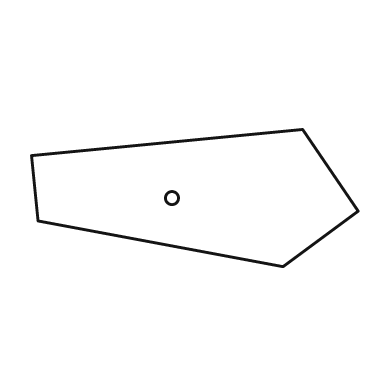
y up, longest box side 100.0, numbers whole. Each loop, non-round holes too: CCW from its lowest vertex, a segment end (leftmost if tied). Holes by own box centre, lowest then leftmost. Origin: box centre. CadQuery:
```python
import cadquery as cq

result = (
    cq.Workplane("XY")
    .moveTo(27.0, -21.0)
    .lineTo(50.0, -4.0)
    .lineTo(33.0, 21.0)
    .lineTo(-50.0, 13.0)
    .lineTo(-48.0, -7.0)
    .close()
    .moveTo(-7.0, 0.0)
    .circle(2.0)
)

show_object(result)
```